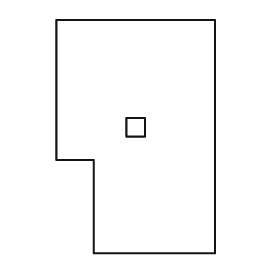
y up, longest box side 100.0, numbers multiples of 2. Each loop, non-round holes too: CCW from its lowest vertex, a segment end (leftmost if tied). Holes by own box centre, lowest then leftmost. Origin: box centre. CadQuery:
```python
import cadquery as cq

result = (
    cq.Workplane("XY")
    .moveTo(-18.0, -50.0)
    .lineTo(34.0, -50.0)
    .lineTo(34.0, 50.0)
    .lineTo(-34.0, 50.0)
    .lineTo(-34.0, -10.0)
    .lineTo(-18.0, -10.0)
    .close()
    .moveTo(-4.0, 0.0)
    .lineTo(4.0, 0.0)
    .lineTo(4.0, 8.0)
    .lineTo(-4.0, 8.0)
    .close()
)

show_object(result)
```